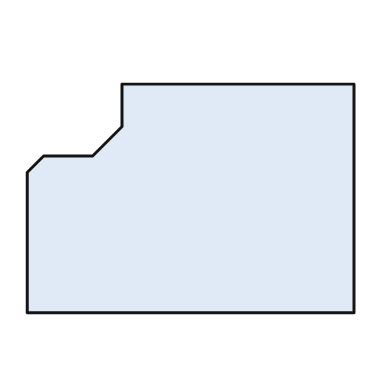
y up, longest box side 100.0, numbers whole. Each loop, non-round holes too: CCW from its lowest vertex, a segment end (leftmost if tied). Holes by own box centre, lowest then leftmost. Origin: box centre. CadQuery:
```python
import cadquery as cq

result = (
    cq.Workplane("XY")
    .moveTo(-50.0, -35.0)
    .lineTo(50.0, -35.0)
    .lineTo(50.0, 35.0)
    .lineTo(-21.0, 35.0)
    .lineTo(-21.0, 22.0)
    .lineTo(-30.0, 13.0)
    .lineTo(-45.0, 13.0)
    .lineTo(-50.0, 8.0)
    .close()
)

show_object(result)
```